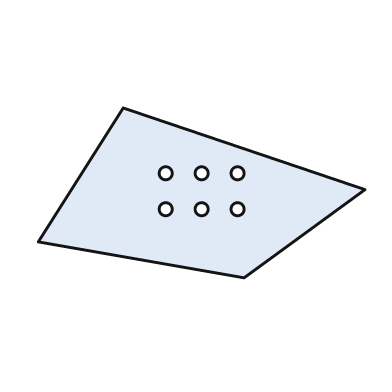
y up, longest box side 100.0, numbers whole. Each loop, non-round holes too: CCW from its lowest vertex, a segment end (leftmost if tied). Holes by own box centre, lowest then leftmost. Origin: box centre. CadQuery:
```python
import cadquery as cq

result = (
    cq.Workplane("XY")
    .moveTo(13.0, -26.0)
    .lineTo(50.0, 1.0)
    .lineTo(-24.0, 26.0)
    .lineTo(-50.0, -15.0)
    .close()
    .moveTo(-11.0, -5.0)
    .circle(2.0)
    .moveTo(0.0, -5.0)
    .circle(2.0)
    .moveTo(11.0, -5.0)
    .circle(2.0)
    .moveTo(-11.0, 6.0)
    .circle(2.0)
    .moveTo(0.0, 6.0)
    .circle(2.0)
    .moveTo(11.0, 6.0)
    .circle(2.0)
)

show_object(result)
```